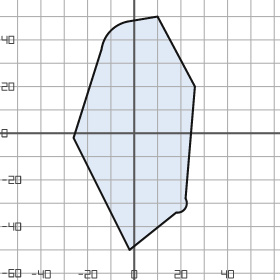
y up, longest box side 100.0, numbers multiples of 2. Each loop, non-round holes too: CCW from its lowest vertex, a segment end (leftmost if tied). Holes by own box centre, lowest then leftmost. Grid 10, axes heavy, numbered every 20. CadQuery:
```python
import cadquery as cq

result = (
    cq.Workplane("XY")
    .moveTo(-2.0, -50.0)
    .lineTo(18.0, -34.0)
    .threePointArc((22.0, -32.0), (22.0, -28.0))
    .lineTo(26.0, 20.0)
    .lineTo(10.0, 50.0)
    .lineTo(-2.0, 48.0)
    .threePointArc((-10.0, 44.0), (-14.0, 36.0))
    .lineTo(-26.0, -2.0)
    .close()
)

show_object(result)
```